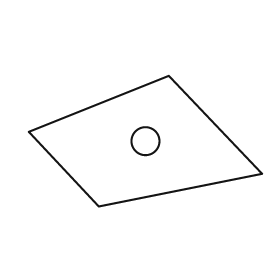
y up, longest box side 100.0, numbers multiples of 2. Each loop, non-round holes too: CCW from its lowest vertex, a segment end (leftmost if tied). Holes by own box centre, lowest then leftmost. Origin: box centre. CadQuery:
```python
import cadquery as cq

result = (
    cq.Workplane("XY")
    .moveTo(-20.0, -28.0)
    .lineTo(50.0, -14.0)
    .lineTo(10.0, 28.0)
    .lineTo(-50.0, 4.0)
    .close()
    .moveTo(0.0, 0.0)
    .circle(6.0)
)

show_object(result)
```